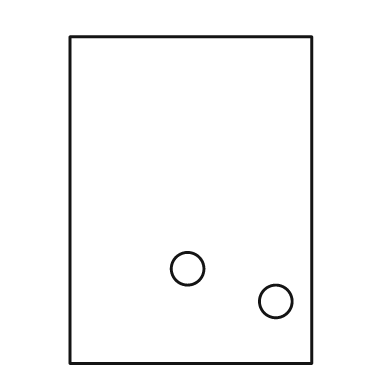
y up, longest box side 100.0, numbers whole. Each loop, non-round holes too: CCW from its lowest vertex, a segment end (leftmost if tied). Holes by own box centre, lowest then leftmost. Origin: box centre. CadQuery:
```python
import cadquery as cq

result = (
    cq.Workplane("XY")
    .moveTo(-37.0, -50.0)
    .lineTo(37.0, -50.0)
    .lineTo(37.0, 50.0)
    .lineTo(-37.0, 50.0)
    .close()
    .moveTo(26.0, -31.0)
    .circle(5.0)
    .moveTo(-1.0, -21.0)
    .circle(5.0)
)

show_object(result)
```